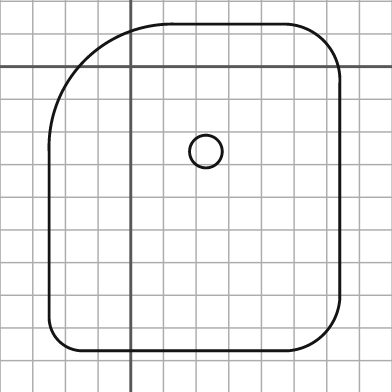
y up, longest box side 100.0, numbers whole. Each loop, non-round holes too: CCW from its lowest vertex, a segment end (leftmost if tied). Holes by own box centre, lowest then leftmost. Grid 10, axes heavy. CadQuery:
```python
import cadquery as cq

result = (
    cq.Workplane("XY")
    .moveTo(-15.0, -87.0)
    .lineTo(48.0, -87.0)
    .threePointArc((59.0, -82.0), (64.0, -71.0))
    .lineTo(64.0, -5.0)
    .threePointArc((59.0, 8.0), (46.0, 13.0))
    .lineTo(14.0, 13.0)
    .threePointArc((-14.0, 2.0), (-25.0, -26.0))
    .lineTo(-25.0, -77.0)
    .threePointArc((-22.0, -84.0), (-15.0, -87.0))
    .close()
    .moveTo(23.0, -26.0)
    .circle(5.0)
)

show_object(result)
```